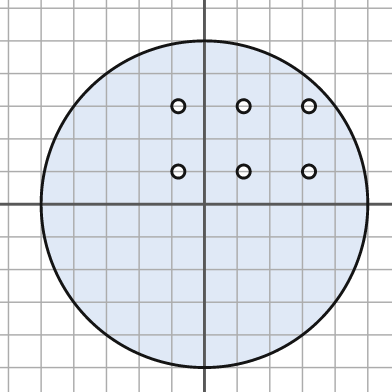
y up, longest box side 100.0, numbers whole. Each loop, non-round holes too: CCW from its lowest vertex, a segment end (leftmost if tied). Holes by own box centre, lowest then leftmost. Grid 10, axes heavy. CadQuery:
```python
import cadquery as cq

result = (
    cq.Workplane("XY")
    .moveTo(0.0, 0.0)
    .circle(50.0)
    .moveTo(-8.0, 10.0)
    .circle(2.0)
    .moveTo(12.0, 10.0)
    .circle(2.0)
    .moveTo(32.0, 10.0)
    .circle(2.0)
    .moveTo(-8.0, 30.0)
    .circle(2.0)
    .moveTo(12.0, 30.0)
    .circle(2.0)
    .moveTo(32.0, 30.0)
    .circle(2.0)
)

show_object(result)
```